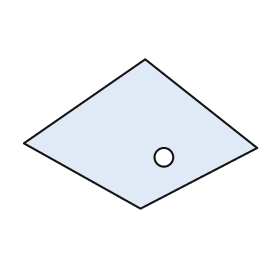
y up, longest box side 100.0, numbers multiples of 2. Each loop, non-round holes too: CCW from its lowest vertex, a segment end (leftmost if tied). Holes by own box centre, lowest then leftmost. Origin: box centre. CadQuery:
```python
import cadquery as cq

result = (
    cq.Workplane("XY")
    .moveTo(0.0, -32.0)
    .lineTo(50.0, -6.0)
    .lineTo(2.0, 32.0)
    .lineTo(-50.0, -4.0)
    .close()
    .moveTo(10.0, -10.0)
    .circle(4.0)
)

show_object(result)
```